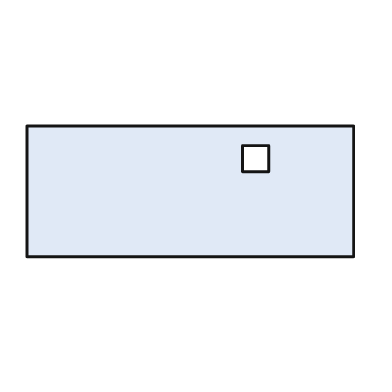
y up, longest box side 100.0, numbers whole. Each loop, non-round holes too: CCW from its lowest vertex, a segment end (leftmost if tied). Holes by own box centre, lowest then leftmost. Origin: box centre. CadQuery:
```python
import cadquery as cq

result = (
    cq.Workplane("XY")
    .moveTo(-50.0, -20.0)
    .lineTo(50.0, -20.0)
    .lineTo(50.0, 20.0)
    .lineTo(-50.0, 20.0)
    .close()
    .moveTo(16.0, 6.0)
    .lineTo(24.0, 6.0)
    .lineTo(24.0, 14.0)
    .lineTo(16.0, 14.0)
    .close()
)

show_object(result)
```